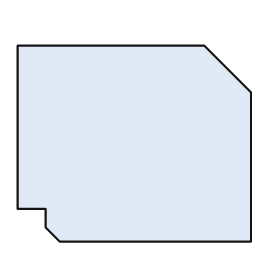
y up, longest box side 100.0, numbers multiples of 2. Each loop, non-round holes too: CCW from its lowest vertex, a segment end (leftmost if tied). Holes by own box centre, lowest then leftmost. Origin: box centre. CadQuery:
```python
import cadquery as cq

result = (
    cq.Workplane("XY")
    .moveTo(-32.0, -42.0)
    .lineTo(50.0, -42.0)
    .lineTo(50.0, 22.0)
    .lineTo(30.0, 42.0)
    .lineTo(-50.0, 42.0)
    .lineTo(-50.0, -28.0)
    .lineTo(-38.0, -28.0)
    .lineTo(-38.0, -36.0)
    .close()
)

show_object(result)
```